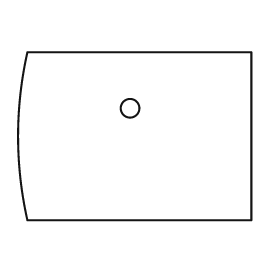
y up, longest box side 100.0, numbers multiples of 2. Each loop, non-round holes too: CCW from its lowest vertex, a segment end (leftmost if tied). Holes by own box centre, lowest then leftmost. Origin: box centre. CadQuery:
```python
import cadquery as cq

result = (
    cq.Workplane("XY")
    .moveTo(-46.0, -36.0)
    .lineTo(50.0, -36.0)
    .lineTo(50.0, 36.0)
    .lineTo(-46.0, 36.0)
    .threePointArc((-50.0, 0.0), (-46.0, -36.0))
    .close()
    .moveTo(-2.0, 12.0)
    .circle(4.0)
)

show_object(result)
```